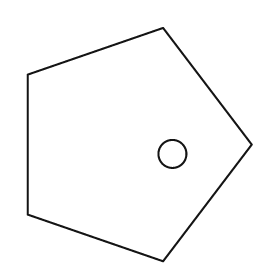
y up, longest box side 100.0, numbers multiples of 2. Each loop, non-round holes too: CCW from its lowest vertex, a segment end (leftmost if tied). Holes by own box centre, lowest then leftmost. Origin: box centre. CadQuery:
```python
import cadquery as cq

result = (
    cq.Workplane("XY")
    .moveTo(10.0, -50.0)
    .lineTo(48.0, 0.0)
    .lineTo(10.0, 50.0)
    .lineTo(-48.0, 30.0)
    .lineTo(-48.0, -30.0)
    .close()
    .moveTo(14.0, -4.0)
    .circle(6.0)
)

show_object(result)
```